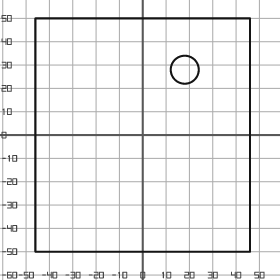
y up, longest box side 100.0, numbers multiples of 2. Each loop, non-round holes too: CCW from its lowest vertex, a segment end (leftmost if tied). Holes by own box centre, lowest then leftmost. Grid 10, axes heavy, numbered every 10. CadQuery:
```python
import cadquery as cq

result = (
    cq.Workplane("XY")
    .moveTo(-46.0, -50.0)
    .lineTo(46.0, -50.0)
    .lineTo(46.0, 50.0)
    .lineTo(-46.0, 50.0)
    .close()
    .moveTo(18.0, 28.0)
    .circle(6.0)
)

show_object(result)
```